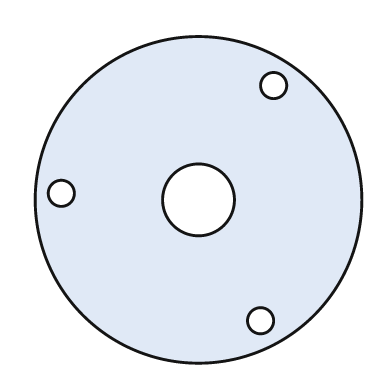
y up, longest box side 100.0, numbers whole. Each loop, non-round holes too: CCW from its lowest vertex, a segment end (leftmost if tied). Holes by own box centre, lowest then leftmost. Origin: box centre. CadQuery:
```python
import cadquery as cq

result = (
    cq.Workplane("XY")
    .moveTo(0.0, 0.0)
    .circle(50.0)
    .moveTo(19.0, -37.0)
    .circle(4.0)
    .moveTo(0.0, 0.0)
    .circle(11.0)
    .moveTo(-42.0, 2.0)
    .circle(4.0)
    .moveTo(23.0, 35.0)
    .circle(4.0)
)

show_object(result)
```